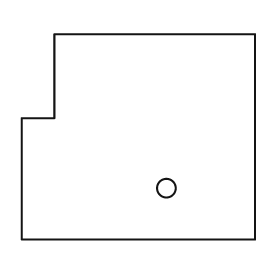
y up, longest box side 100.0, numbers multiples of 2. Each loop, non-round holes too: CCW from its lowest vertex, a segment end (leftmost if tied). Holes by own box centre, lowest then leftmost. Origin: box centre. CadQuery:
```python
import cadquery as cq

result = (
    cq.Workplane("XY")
    .moveTo(-50.0, -44.0)
    .lineTo(50.0, -44.0)
    .lineTo(50.0, 44.0)
    .lineTo(-36.0, 44.0)
    .lineTo(-36.0, 8.0)
    .lineTo(-50.0, 8.0)
    .close()
    .moveTo(12.0, -22.0)
    .circle(4.0)
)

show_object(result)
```